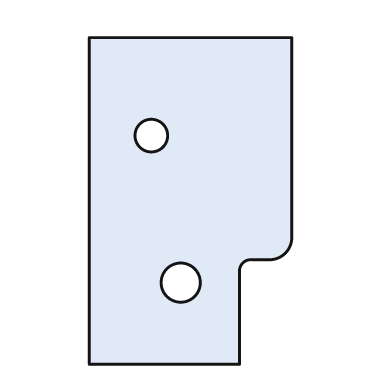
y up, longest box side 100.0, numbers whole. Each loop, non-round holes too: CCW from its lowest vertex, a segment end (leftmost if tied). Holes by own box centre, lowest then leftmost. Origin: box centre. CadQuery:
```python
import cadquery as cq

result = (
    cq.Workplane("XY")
    .moveTo(-31.0, -50.0)
    .lineTo(15.0, -50.0)
    .lineTo(15.0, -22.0)
    .threePointArc((16.0, -19.0), (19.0, -18.0))
    .lineTo(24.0, -18.0)
    .threePointArc((29.0, -16.0), (31.0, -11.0))
    .lineTo(31.0, 50.0)
    .lineTo(-31.0, 50.0)
    .close()
    .moveTo(-3.0, -25.0)
    .circle(6.0)
    .moveTo(-12.0, 20.0)
    .circle(5.0)
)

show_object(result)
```